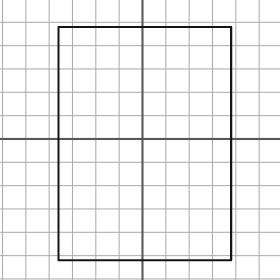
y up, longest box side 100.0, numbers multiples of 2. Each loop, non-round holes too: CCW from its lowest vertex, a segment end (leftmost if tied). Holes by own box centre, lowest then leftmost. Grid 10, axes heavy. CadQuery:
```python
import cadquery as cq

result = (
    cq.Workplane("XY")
    .moveTo(-36.0, -52.0)
    .lineTo(38.0, -52.0)
    .lineTo(38.0, 48.0)
    .lineTo(-36.0, 48.0)
    .close()
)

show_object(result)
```